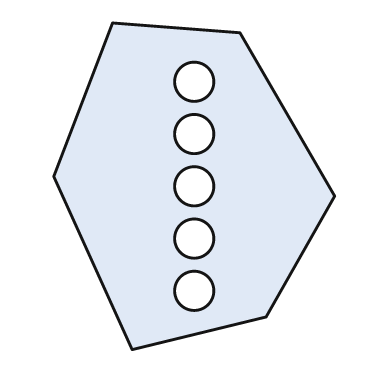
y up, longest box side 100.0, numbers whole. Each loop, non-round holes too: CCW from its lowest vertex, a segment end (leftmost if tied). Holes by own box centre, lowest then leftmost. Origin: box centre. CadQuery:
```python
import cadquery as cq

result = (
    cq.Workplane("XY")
    .moveTo(-19.0, -50.0)
    .lineTo(22.0, -40.0)
    .lineTo(43.0, -3.0)
    .lineTo(14.0, 47.0)
    .lineTo(-25.0, 50.0)
    .lineTo(-43.0, 3.0)
    .close()
    .moveTo(0.0, -32.0)
    .circle(6.0)
    .moveTo(0.0, -16.0)
    .circle(6.0)
    .moveTo(0.0, 0.0)
    .circle(6.0)
    .moveTo(0.0, 16.0)
    .circle(6.0)
    .moveTo(0.0, 32.0)
    .circle(6.0)
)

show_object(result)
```